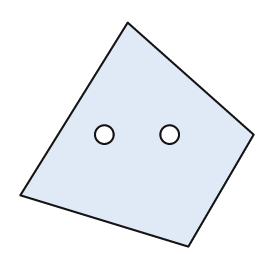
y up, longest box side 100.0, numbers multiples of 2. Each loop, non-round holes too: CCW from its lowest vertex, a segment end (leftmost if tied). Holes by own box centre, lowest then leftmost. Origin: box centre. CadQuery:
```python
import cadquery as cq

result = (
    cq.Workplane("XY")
    .moveTo(22.0, -48.0)
    .lineTo(50.0, 0.0)
    .lineTo(-4.0, 48.0)
    .lineTo(-50.0, -26.0)
    .close()
    .moveTo(-14.0, 0.0)
    .circle(4.0)
    .moveTo(14.0, 0.0)
    .circle(4.0)
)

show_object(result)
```